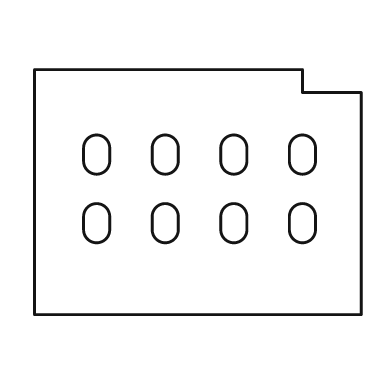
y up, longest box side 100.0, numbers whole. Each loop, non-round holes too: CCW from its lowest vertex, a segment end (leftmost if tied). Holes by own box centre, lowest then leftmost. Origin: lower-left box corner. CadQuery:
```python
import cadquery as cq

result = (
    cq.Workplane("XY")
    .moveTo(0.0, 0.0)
    .lineTo(100.0, 0.0)
    .lineTo(100.0, 68.0)
    .lineTo(82.0, 68.0)
    .lineTo(82.0, 75.0)
    .lineTo(0.0, 75.0)
    .close()
    .moveTo(15.0, 26.0)
    .threePointArc((19.0, 22.0), (23.0, 26.0))
    .lineTo(23.0, 30.0)
    .threePointArc((19.0, 34.0), (15.0, 30.0))
    .close()
    .moveTo(36.0, 26.0)
    .threePointArc((40.0, 22.0), (44.0, 26.0))
    .lineTo(44.0, 30.0)
    .threePointArc((40.0, 34.0), (36.0, 30.0))
    .close()
    .moveTo(57.0, 26.0)
    .threePointArc((61.0, 22.0), (65.0, 26.0))
    .lineTo(65.0, 30.0)
    .threePointArc((61.0, 34.0), (57.0, 30.0))
    .close()
    .moveTo(78.0, 26.0)
    .threePointArc((82.0, 22.0), (86.0, 26.0))
    .lineTo(86.0, 30.0)
    .threePointArc((82.0, 34.0), (78.0, 30.0))
    .close()
    .moveTo(15.0, 47.0)
    .threePointArc((19.0, 43.0), (23.0, 47.0))
    .lineTo(23.0, 51.0)
    .threePointArc((19.0, 55.0), (15.0, 51.0))
    .close()
    .moveTo(36.0, 47.0)
    .threePointArc((40.0, 43.0), (44.0, 47.0))
    .lineTo(44.0, 51.0)
    .threePointArc((40.0, 55.0), (36.0, 51.0))
    .close()
    .moveTo(57.0, 47.0)
    .threePointArc((61.0, 43.0), (65.0, 47.0))
    .lineTo(65.0, 51.0)
    .threePointArc((61.0, 55.0), (57.0, 51.0))
    .close()
    .moveTo(78.0, 47.0)
    .threePointArc((82.0, 43.0), (86.0, 47.0))
    .lineTo(86.0, 51.0)
    .threePointArc((82.0, 55.0), (78.0, 51.0))
    .close()
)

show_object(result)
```